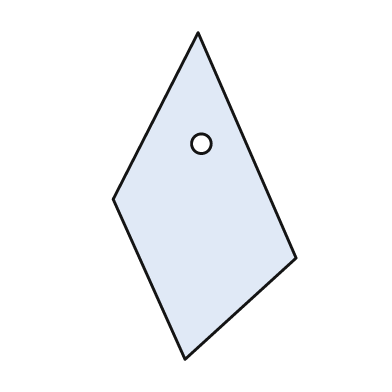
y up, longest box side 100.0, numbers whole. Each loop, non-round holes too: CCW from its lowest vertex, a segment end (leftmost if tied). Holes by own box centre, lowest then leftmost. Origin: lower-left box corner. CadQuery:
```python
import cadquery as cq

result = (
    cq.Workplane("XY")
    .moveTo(22.0, 0.0)
    .lineTo(56.0, 31.0)
    .lineTo(26.0, 100.0)
    .lineTo(0.0, 49.0)
    .close()
    .moveTo(27.0, 66.0)
    .circle(3.0)
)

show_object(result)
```